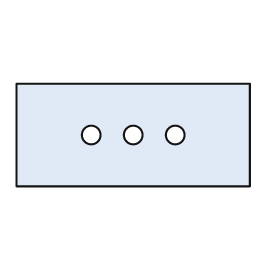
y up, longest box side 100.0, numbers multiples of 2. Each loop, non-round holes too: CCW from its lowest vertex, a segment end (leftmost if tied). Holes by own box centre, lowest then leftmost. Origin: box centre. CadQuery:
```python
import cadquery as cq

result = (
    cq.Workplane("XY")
    .moveTo(-50.0, -22.0)
    .lineTo(50.0, -22.0)
    .lineTo(50.0, 22.0)
    .lineTo(-50.0, 22.0)
    .close()
    .moveTo(-18.0, 0.0)
    .circle(4.0)
    .moveTo(0.0, 0.0)
    .circle(4.0)
    .moveTo(18.0, 0.0)
    .circle(4.0)
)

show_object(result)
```